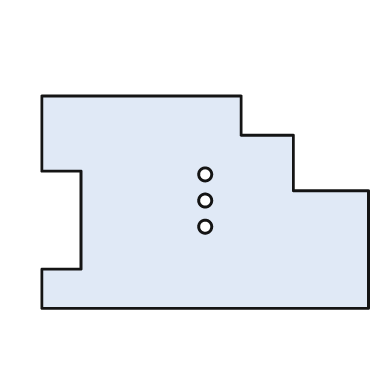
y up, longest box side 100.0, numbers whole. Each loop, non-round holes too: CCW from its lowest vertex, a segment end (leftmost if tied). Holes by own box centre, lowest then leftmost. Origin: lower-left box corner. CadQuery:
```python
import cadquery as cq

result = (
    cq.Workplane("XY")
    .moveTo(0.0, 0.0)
    .lineTo(100.0, 0.0)
    .lineTo(100.0, 36.0)
    .lineTo(77.0, 36.0)
    .lineTo(77.0, 53.0)
    .lineTo(61.0, 53.0)
    .lineTo(61.0, 65.0)
    .lineTo(0.0, 65.0)
    .lineTo(0.0, 42.0)
    .lineTo(12.0, 42.0)
    .lineTo(12.0, 12.0)
    .lineTo(0.0, 12.0)
    .close()
    .moveTo(50.0, 25.0)
    .circle(2.0)
    .moveTo(50.0, 33.0)
    .circle(2.0)
    .moveTo(50.0, 41.0)
    .circle(2.0)
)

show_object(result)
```